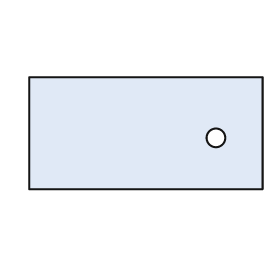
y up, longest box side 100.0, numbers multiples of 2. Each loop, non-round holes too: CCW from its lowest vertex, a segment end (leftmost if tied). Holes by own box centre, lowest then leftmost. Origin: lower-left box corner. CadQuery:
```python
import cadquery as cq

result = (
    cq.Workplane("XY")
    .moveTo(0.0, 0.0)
    .lineTo(100.0, 0.0)
    .lineTo(100.0, 48.0)
    .lineTo(0.0, 48.0)
    .close()
    .moveTo(80.0, 22.0)
    .circle(4.0)
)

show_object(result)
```